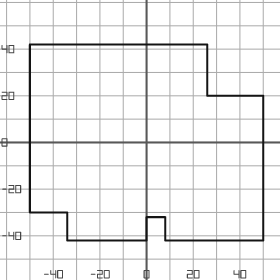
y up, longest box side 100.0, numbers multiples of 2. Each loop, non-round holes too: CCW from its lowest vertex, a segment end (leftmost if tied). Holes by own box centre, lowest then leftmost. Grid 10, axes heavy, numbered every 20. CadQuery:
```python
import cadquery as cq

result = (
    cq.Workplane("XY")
    .moveTo(-34.0, -42.0)
    .lineTo(0.0, -42.0)
    .lineTo(0.0, -32.0)
    .lineTo(8.0, -32.0)
    .lineTo(8.0, -42.0)
    .lineTo(50.0, -42.0)
    .lineTo(50.0, 20.0)
    .lineTo(26.0, 20.0)
    .lineTo(26.0, 42.0)
    .lineTo(-50.0, 42.0)
    .lineTo(-50.0, -30.0)
    .lineTo(-34.0, -30.0)
    .close()
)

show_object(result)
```